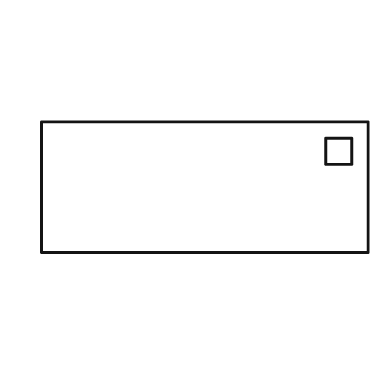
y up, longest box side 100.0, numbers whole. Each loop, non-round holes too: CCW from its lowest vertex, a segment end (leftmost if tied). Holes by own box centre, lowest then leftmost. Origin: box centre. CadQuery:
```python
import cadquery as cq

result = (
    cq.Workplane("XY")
    .moveTo(-50.0, -20.0)
    .lineTo(50.0, -20.0)
    .lineTo(50.0, 20.0)
    .lineTo(-50.0, 20.0)
    .close()
    .moveTo(37.0, 7.0)
    .lineTo(45.0, 7.0)
    .lineTo(45.0, 15.0)
    .lineTo(37.0, 15.0)
    .close()
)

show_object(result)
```